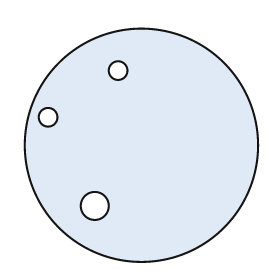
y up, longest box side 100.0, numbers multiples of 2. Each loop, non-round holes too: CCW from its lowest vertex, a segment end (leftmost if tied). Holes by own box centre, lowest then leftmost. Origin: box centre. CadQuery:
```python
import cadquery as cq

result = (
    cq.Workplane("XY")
    .moveTo(0.0, 0.0)
    .circle(50.0)
    .moveTo(-20.0, -26.0)
    .circle(6.0)
    .moveTo(-40.0, 12.0)
    .circle(4.0)
    .moveTo(-10.0, 32.0)
    .circle(4.0)
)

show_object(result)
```